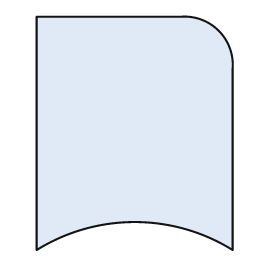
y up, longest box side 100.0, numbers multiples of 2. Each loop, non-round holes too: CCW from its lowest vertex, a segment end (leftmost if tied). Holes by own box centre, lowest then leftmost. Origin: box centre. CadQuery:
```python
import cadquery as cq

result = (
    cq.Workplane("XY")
    .moveTo(-42.0, -50.0)
    .threePointArc((0.0, -38.0), (42.0, -50.0))
    .lineTo(42.0, 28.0)
    .threePointArc((36.0, 44.0), (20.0, 50.0))
    .lineTo(-42.0, 50.0)
    .close()
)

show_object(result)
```